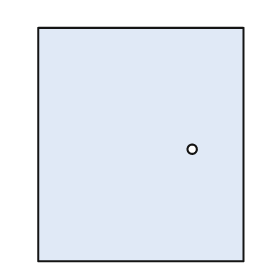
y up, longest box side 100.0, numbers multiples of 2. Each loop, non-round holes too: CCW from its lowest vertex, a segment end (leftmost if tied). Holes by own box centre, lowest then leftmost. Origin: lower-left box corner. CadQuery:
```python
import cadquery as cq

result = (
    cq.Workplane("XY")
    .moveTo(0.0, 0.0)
    .lineTo(88.0, 0.0)
    .lineTo(88.0, 100.0)
    .lineTo(0.0, 100.0)
    .close()
    .moveTo(66.0, 48.0)
    .circle(2.0)
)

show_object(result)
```